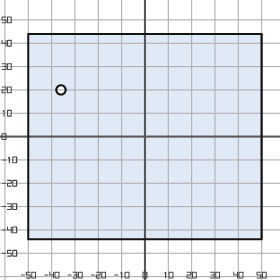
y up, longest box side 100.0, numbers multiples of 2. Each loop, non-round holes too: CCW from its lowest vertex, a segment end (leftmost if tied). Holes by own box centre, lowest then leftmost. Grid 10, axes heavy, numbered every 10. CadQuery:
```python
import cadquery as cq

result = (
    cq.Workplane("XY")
    .moveTo(-50.0, -44.0)
    .lineTo(50.0, -44.0)
    .lineTo(50.0, 44.0)
    .lineTo(-50.0, 44.0)
    .close()
    .moveTo(-36.0, 20.0)
    .circle(2.0)
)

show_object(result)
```